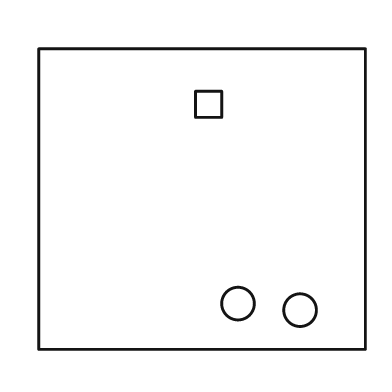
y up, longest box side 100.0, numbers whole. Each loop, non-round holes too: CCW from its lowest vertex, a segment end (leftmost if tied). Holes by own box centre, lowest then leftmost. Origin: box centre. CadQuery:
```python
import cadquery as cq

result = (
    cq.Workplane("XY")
    .moveTo(-50.0, -46.0)
    .lineTo(50.0, -46.0)
    .lineTo(50.0, 46.0)
    .lineTo(-50.0, 46.0)
    .close()
    .moveTo(30.0, -34.0)
    .circle(5.0)
    .moveTo(11.0, -32.0)
    .circle(5.0)
    .moveTo(-2.0, 25.0)
    .lineTo(6.0, 25.0)
    .lineTo(6.0, 33.0)
    .lineTo(-2.0, 33.0)
    .close()
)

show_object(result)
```